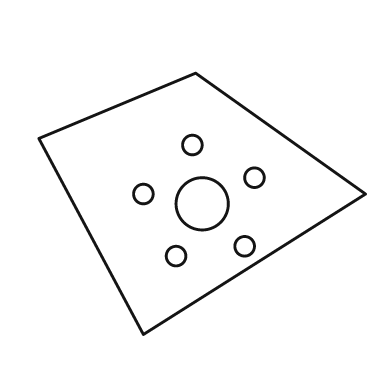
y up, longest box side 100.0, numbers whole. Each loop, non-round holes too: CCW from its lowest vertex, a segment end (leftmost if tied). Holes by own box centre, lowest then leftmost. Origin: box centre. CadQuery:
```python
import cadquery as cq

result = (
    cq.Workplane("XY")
    .moveTo(-18.0, -40.0)
    .lineTo(50.0, 3.0)
    .lineTo(-2.0, 40.0)
    .lineTo(-50.0, 20.0)
    .close()
    .moveTo(-8.0, -16.0)
    .circle(3.0)
    .moveTo(13.0, -13.0)
    .circle(3.0)
    .moveTo(0.0, 0.0)
    .circle(8.0)
    .moveTo(-18.0, 3.0)
    .circle(3.0)
    .moveTo(16.0, 8.0)
    .circle(3.0)
    .moveTo(-3.0, 18.0)
    .circle(3.0)
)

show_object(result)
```